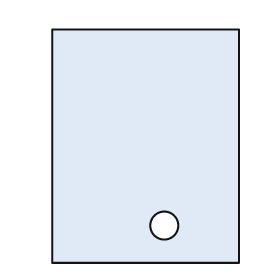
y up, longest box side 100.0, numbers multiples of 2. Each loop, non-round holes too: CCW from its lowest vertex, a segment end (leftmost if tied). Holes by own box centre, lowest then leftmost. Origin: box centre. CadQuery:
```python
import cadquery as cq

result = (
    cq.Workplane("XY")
    .moveTo(-40.0, -50.0)
    .lineTo(40.0, -50.0)
    .lineTo(40.0, 50.0)
    .lineTo(-40.0, 50.0)
    .close()
    .moveTo(8.0, -34.0)
    .circle(6.0)
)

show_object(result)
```